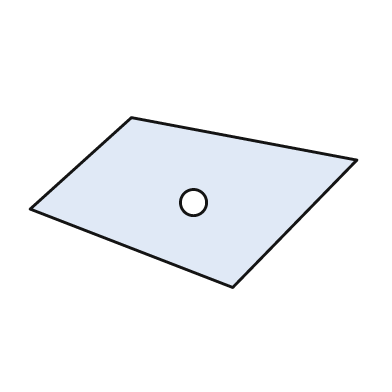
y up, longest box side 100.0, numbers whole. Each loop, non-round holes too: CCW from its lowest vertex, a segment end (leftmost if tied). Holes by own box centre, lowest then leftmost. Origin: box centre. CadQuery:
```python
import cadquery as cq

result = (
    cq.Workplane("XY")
    .moveTo(12.0, -26.0)
    .lineTo(50.0, 13.0)
    .lineTo(-19.0, 26.0)
    .lineTo(-50.0, -2.0)
    .close()
    .moveTo(0.0, 0.0)
    .circle(4.0)
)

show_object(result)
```